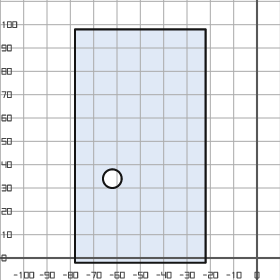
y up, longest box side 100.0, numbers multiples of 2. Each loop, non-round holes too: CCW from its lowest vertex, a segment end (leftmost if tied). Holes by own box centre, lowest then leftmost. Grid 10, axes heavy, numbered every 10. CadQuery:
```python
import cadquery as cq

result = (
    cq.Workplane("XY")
    .moveTo(-78.0, -2.0)
    .lineTo(-22.0, -2.0)
    .lineTo(-22.0, 98.0)
    .lineTo(-78.0, 98.0)
    .close()
    .moveTo(-62.0, 34.0)
    .circle(4.0)
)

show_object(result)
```